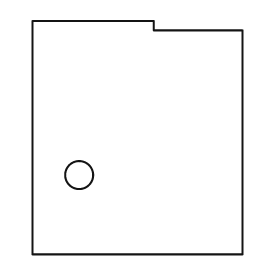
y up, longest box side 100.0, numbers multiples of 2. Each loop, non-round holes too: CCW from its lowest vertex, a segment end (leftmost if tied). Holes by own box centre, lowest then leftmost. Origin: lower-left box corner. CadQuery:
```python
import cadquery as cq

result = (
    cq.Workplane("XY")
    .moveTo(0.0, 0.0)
    .lineTo(90.0, 0.0)
    .lineTo(90.0, 96.0)
    .lineTo(52.0, 96.0)
    .lineTo(52.0, 100.0)
    .lineTo(0.0, 100.0)
    .close()
    .moveTo(20.0, 34.0)
    .circle(6.0)
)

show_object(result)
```